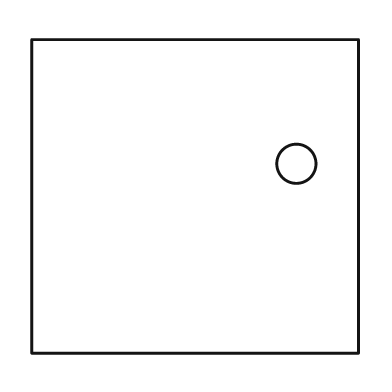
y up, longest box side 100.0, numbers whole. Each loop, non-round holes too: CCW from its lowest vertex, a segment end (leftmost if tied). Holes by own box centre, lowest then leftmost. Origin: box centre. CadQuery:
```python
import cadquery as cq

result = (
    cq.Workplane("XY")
    .moveTo(-50.0, -48.0)
    .lineTo(50.0, -48.0)
    .lineTo(50.0, 48.0)
    .lineTo(-50.0, 48.0)
    .close()
    .moveTo(31.0, 10.0)
    .circle(6.0)
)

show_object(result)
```